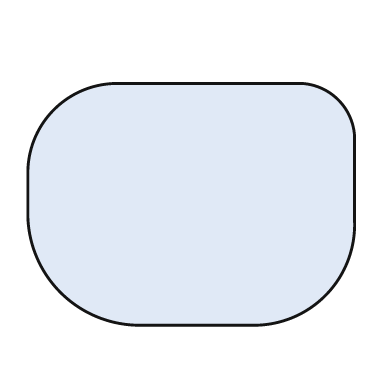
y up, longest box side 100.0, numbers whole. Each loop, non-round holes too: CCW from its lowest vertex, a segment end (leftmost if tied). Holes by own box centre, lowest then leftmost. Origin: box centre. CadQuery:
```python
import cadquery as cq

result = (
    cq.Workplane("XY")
    .moveTo(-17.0, -37.0)
    .lineTo(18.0, -37.0)
    .threePointArc((41.0, -28.0), (50.0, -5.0))
    .lineTo(50.0, 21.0)
    .threePointArc((45.0, 32.0), (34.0, 37.0))
    .lineTo(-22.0, 37.0)
    .threePointArc((-42.0, 29.0), (-50.0, 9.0))
    .lineTo(-50.0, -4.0)
    .threePointArc((-40.0, -27.0), (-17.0, -37.0))
    .close()
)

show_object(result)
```